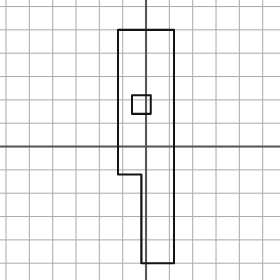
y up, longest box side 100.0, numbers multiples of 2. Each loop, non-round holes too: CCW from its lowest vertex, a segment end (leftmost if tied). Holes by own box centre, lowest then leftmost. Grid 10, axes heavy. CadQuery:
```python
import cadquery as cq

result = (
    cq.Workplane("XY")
    .moveTo(-2.0, -50.0)
    .lineTo(12.0, -50.0)
    .lineTo(12.0, 50.0)
    .lineTo(-12.0, 50.0)
    .lineTo(-12.0, -12.0)
    .lineTo(-2.0, -12.0)
    .close()
    .moveTo(-6.0, 14.0)
    .lineTo(2.0, 14.0)
    .lineTo(2.0, 22.0)
    .lineTo(-6.0, 22.0)
    .close()
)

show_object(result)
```